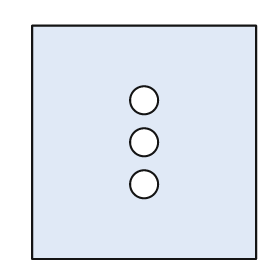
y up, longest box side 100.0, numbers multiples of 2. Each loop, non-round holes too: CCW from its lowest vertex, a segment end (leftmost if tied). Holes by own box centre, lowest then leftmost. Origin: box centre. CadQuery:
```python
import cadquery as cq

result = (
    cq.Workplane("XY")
    .moveTo(-48.0, -50.0)
    .lineTo(48.0, -50.0)
    .lineTo(48.0, 50.0)
    .lineTo(-48.0, 50.0)
    .close()
    .moveTo(0.0, -18.0)
    .circle(6.0)
    .moveTo(0.0, 0.0)
    .circle(6.0)
    .moveTo(0.0, 18.0)
    .circle(6.0)
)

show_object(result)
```